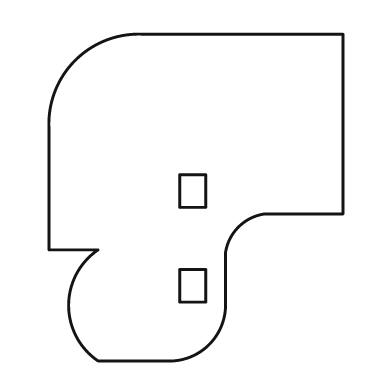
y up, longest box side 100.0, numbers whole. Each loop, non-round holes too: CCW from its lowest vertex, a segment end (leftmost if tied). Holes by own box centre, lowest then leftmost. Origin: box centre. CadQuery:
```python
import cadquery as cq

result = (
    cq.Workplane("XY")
    .moveTo(-30.0, -50.0)
    .lineTo(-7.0, -50.0)
    .threePointArc((4.0, -45.0), (9.0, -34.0))
    .lineTo(9.0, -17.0)
    .threePointArc((13.0, -9.0), (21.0, -5.0))
    .lineTo(45.0, -5.0)
    .lineTo(45.0, 50.0)
    .lineTo(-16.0, 50.0)
    .threePointArc((-37.0, 42.0), (-45.0, 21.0))
    .lineTo(-45.0, -16.0)
    .lineTo(-30.0, -16.0)
    .threePointArc((-39.0, -33.0), (-30.0, -50.0))
    .close()
    .moveTo(-5.0, -32.0)
    .lineTo(3.0, -32.0)
    .lineTo(3.0, -22.0)
    .lineTo(-5.0, -22.0)
    .close()
    .moveTo(-5.0, -3.0)
    .lineTo(3.0, -3.0)
    .lineTo(3.0, 7.0)
    .lineTo(-5.0, 7.0)
    .close()
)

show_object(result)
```